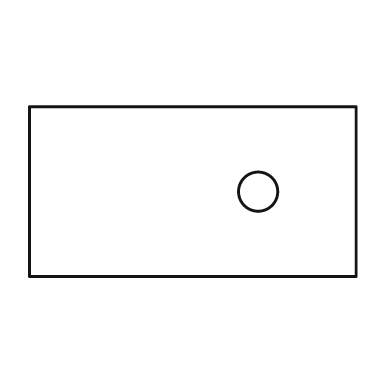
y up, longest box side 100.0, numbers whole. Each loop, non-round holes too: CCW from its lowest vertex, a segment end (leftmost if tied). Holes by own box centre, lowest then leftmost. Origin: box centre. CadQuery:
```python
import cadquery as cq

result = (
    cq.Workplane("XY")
    .moveTo(-50.0, -26.0)
    .lineTo(50.0, -26.0)
    .lineTo(50.0, 26.0)
    .lineTo(-50.0, 26.0)
    .close()
    .moveTo(20.0, 0.0)
    .circle(6.0)
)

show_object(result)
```